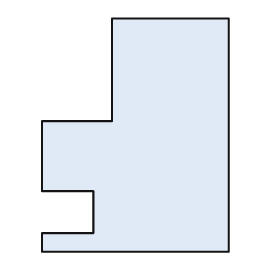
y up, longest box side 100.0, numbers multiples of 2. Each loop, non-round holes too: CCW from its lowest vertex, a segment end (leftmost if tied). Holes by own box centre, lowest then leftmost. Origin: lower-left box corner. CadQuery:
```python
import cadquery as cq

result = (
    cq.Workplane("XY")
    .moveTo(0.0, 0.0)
    .lineTo(80.0, 0.0)
    .lineTo(80.0, 100.0)
    .lineTo(30.0, 100.0)
    .lineTo(30.0, 56.0)
    .lineTo(0.0, 56.0)
    .lineTo(0.0, 26.0)
    .lineTo(22.0, 26.0)
    .lineTo(22.0, 8.0)
    .lineTo(0.0, 8.0)
    .close()
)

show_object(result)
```